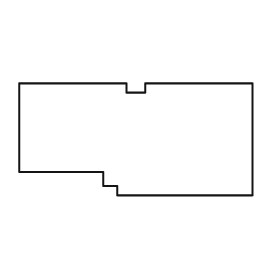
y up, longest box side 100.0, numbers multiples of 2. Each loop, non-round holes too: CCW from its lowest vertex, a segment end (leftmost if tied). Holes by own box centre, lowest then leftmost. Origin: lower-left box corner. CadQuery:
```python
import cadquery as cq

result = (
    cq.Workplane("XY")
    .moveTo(42.0, 0.0)
    .lineTo(100.0, 0.0)
    .lineTo(100.0, 48.0)
    .lineTo(54.0, 48.0)
    .lineTo(54.0, 44.0)
    .lineTo(46.0, 44.0)
    .lineTo(46.0, 48.0)
    .lineTo(0.0, 48.0)
    .lineTo(0.0, 10.0)
    .lineTo(36.0, 10.0)
    .lineTo(36.0, 4.0)
    .lineTo(42.0, 4.0)
    .close()
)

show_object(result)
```